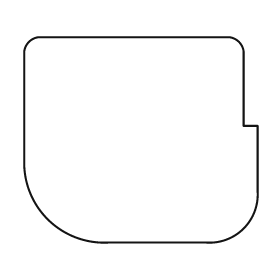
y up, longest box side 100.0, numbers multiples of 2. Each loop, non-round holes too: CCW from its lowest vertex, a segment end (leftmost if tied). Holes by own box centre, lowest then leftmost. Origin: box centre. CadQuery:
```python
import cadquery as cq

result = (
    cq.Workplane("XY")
    .moveTo(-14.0, -44.0)
    .lineTo(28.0, -44.0)
    .threePointArc((44.0, -38.0), (50.0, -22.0))
    .lineTo(50.0, 6.0)
    .lineTo(44.0, 6.0)
    .lineTo(44.0, 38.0)
    .threePointArc((42.0, 42.0), (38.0, 44.0))
    .lineTo(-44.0, 44.0)
    .threePointArc((-48.0, 42.0), (-50.0, 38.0))
    .lineTo(-50.0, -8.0)
    .threePointArc((-40.0, -34.0), (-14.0, -44.0))
    .close()
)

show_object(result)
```